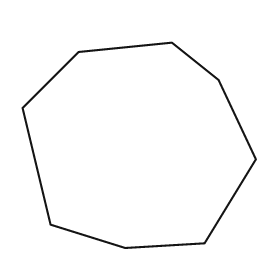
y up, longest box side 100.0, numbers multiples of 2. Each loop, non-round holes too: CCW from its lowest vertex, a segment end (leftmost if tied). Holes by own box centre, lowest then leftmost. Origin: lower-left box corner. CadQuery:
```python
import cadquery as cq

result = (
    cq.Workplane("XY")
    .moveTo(44.0, 0.0)
    .lineTo(78.0, 2.0)
    .lineTo(100.0, 38.0)
    .lineTo(84.0, 72.0)
    .lineTo(64.0, 88.0)
    .lineTo(24.0, 84.0)
    .lineTo(0.0, 60.0)
    .lineTo(12.0, 10.0)
    .close()
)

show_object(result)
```